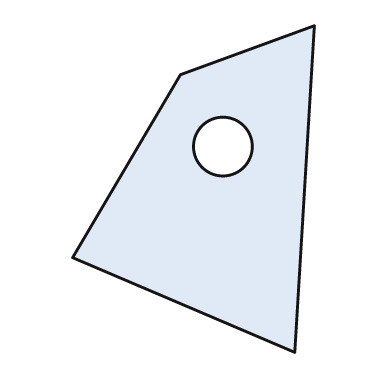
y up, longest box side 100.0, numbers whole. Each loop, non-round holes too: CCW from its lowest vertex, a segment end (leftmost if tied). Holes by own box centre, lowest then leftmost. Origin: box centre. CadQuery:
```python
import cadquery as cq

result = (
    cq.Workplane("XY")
    .moveTo(31.0, -50.0)
    .lineTo(37.0, 50.0)
    .lineTo(-4.0, 35.0)
    .lineTo(-37.0, -21.0)
    .close()
    .moveTo(9.0, 13.0)
    .circle(9.0)
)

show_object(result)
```